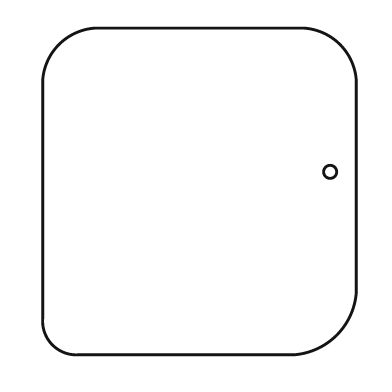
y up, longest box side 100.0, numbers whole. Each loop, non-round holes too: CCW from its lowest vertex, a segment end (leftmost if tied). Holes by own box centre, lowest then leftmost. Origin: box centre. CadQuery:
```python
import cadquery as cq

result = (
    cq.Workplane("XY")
    .moveTo(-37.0, -50.0)
    .lineTo(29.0, -50.0)
    .threePointArc((42.0, -44.0), (48.0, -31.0))
    .lineTo(48.0, 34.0)
    .threePointArc((43.0, 45.0), (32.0, 50.0))
    .lineTo(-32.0, 50.0)
    .threePointArc((-43.0, 45.0), (-48.0, 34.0))
    .lineTo(-48.0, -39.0)
    .threePointArc((-45.0, -47.0), (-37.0, -50.0))
    .close()
    .moveTo(40.0, 6.0)
    .circle(2.0)
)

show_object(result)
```